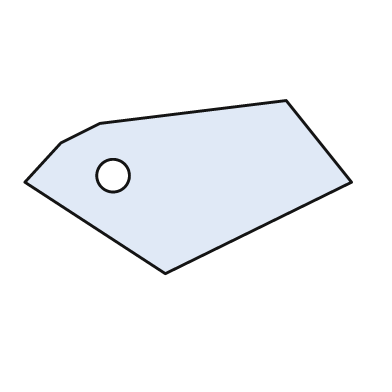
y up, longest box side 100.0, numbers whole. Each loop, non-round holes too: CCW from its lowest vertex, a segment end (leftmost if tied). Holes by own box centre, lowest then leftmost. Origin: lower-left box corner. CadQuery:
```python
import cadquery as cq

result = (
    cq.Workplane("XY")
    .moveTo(43.0, 0.0)
    .lineTo(100.0, 28.0)
    .lineTo(80.0, 53.0)
    .lineTo(23.0, 46.0)
    .lineTo(11.0, 40.0)
    .lineTo(0.0, 28.0)
    .close()
    .moveTo(27.0, 30.0)
    .circle(5.0)
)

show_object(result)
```